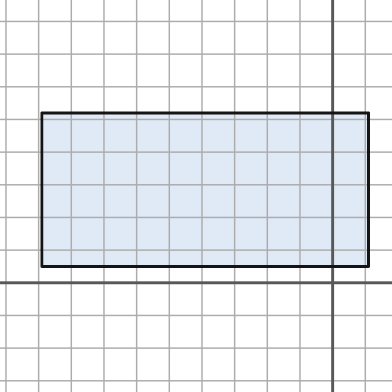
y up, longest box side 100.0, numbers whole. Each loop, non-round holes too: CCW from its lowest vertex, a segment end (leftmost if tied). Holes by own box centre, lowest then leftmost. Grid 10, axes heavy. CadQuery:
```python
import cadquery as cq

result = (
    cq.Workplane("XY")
    .moveTo(-89.0, 5.0)
    .lineTo(11.0, 5.0)
    .lineTo(11.0, 52.0)
    .lineTo(-89.0, 52.0)
    .close()
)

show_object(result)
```